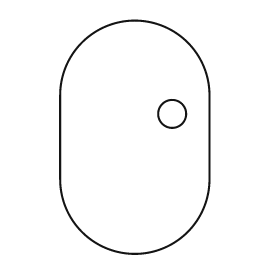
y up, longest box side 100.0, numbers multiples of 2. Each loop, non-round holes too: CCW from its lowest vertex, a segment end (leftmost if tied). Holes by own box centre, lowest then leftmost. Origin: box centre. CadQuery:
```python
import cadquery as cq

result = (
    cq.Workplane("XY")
    .moveTo(-32.0, -18.0)
    .threePointArc((0.0, -50.0), (32.0, -18.0))
    .lineTo(32.0, 18.0)
    .threePointArc((0.0, 50.0), (-32.0, 18.0))
    .close()
    .moveTo(16.0, 10.0)
    .circle(6.0)
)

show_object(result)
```